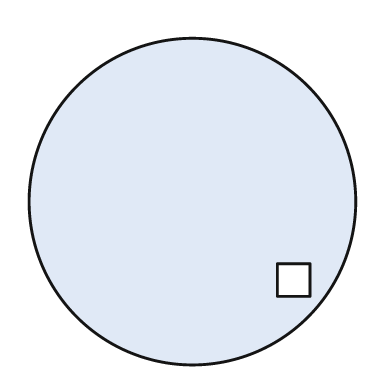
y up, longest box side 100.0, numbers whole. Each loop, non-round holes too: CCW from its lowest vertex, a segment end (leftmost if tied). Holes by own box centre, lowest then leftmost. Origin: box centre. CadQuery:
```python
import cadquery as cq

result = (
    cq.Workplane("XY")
    .moveTo(0.0, 0.0)
    .circle(50.0)
    .moveTo(26.0, -29.0)
    .lineTo(36.0, -29.0)
    .lineTo(36.0, -19.0)
    .lineTo(26.0, -19.0)
    .close()
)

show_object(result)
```